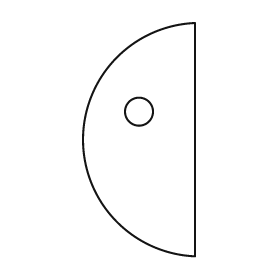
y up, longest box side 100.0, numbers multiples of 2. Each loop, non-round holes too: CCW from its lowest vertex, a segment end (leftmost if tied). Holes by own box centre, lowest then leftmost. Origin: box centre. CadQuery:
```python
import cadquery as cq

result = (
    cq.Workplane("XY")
    .moveTo(24.0, -50.0)
    .lineTo(24.0, 50.0)
    .threePointArc((-24.0, 0.0), (24.0, -50.0))
    .close()
    .moveTo(0.0, 12.0)
    .circle(6.0)
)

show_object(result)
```